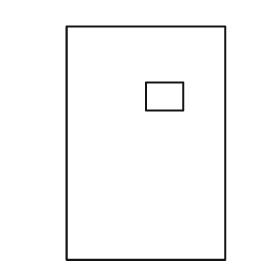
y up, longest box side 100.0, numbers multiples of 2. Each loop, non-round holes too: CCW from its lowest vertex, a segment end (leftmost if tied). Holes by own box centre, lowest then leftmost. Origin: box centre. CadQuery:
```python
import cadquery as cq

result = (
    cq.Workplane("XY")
    .moveTo(-34.0, -50.0)
    .lineTo(34.0, -50.0)
    .lineTo(34.0, 50.0)
    .lineTo(-34.0, 50.0)
    .close()
    .moveTo(0.0, 14.0)
    .lineTo(16.0, 14.0)
    .lineTo(16.0, 26.0)
    .lineTo(0.0, 26.0)
    .close()
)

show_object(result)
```